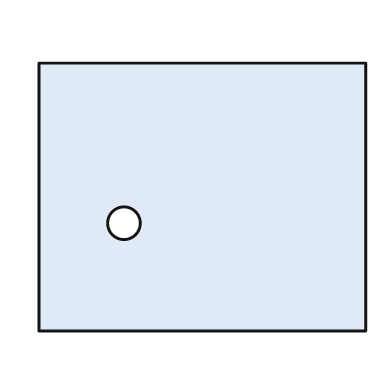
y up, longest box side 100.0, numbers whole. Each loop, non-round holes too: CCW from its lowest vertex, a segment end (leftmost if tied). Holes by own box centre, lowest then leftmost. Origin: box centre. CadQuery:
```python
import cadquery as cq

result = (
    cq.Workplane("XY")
    .moveTo(-50.0, -41.0)
    .lineTo(50.0, -41.0)
    .lineTo(50.0, 41.0)
    .lineTo(-50.0, 41.0)
    .close()
    .moveTo(-24.0, -8.0)
    .circle(5.0)
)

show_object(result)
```